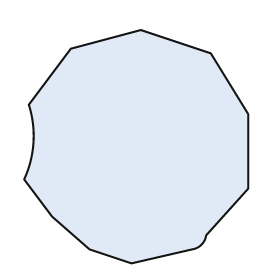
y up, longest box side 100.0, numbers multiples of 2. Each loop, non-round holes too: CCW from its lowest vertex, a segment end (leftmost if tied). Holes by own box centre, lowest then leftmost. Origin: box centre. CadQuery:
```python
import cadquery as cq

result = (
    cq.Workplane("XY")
    .moveTo(-2.0, -50.0)
    .lineTo(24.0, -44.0)
    .threePointArc((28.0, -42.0), (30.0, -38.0))
    .lineTo(48.0, -18.0)
    .lineTo(48.0, 14.0)
    .lineTo(32.0, 40.0)
    .lineTo(2.0, 50.0)
    .lineTo(-28.0, 42.0)
    .lineTo(-46.0, 18.0)
    .threePointArc((-44.0, 2.0), (-48.0, -14.0))
    .lineTo(-36.0, -30.0)
    .lineTo(-20.0, -44.0)
    .close()
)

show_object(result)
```